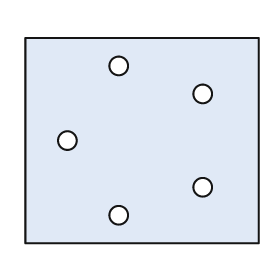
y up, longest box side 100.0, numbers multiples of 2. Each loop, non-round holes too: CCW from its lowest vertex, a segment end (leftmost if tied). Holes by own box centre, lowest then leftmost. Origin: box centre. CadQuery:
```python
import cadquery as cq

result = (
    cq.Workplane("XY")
    .moveTo(-50.0, -44.0)
    .lineTo(50.0, -44.0)
    .lineTo(50.0, 44.0)
    .lineTo(-50.0, 44.0)
    .close()
    .moveTo(-10.0, -32.0)
    .circle(4.0)
    .moveTo(26.0, -20.0)
    .circle(4.0)
    .moveTo(-32.0, 0.0)
    .circle(4.0)
    .moveTo(26.0, 20.0)
    .circle(4.0)
    .moveTo(-10.0, 32.0)
    .circle(4.0)
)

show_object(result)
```